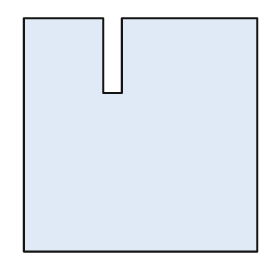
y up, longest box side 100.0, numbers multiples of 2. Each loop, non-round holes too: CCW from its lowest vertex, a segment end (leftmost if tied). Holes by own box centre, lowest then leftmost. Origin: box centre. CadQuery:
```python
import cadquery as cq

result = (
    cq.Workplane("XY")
    .moveTo(-50.0, -50.0)
    .lineTo(50.0, -50.0)
    .lineTo(50.0, 50.0)
    .lineTo(-8.0, 50.0)
    .lineTo(-8.0, 18.0)
    .lineTo(-16.0, 18.0)
    .lineTo(-16.0, 50.0)
    .lineTo(-50.0, 50.0)
    .close()
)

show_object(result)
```